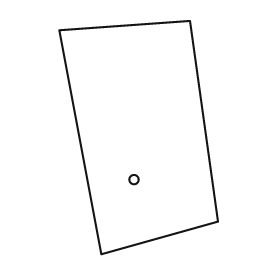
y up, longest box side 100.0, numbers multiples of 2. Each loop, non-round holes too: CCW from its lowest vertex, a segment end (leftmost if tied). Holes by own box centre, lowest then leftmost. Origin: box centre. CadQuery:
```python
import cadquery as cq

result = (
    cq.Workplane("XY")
    .moveTo(-16.0, -50.0)
    .lineTo(34.0, -36.0)
    .lineTo(22.0, 50.0)
    .lineTo(-34.0, 46.0)
    .close()
    .moveTo(-2.0, -18.0)
    .circle(2.0)
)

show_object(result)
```